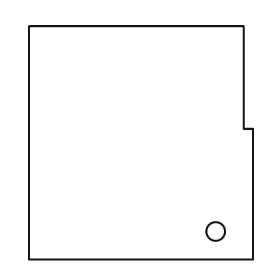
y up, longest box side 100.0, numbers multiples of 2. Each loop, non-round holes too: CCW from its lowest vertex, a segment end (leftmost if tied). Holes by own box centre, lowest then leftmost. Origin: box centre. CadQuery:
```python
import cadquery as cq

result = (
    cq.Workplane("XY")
    .moveTo(-48.0, -50.0)
    .lineTo(48.0, -50.0)
    .lineTo(48.0, 6.0)
    .lineTo(44.0, 6.0)
    .lineTo(44.0, 50.0)
    .lineTo(-48.0, 50.0)
    .close()
    .moveTo(32.0, -38.0)
    .circle(4.0)
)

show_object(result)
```